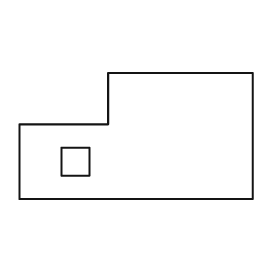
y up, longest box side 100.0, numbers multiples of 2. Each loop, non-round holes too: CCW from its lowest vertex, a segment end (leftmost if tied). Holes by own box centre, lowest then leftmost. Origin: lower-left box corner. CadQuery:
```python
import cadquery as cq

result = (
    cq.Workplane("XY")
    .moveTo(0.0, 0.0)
    .lineTo(100.0, 0.0)
    .lineTo(100.0, 54.0)
    .lineTo(38.0, 54.0)
    .lineTo(38.0, 32.0)
    .lineTo(0.0, 32.0)
    .close()
    .moveTo(18.0, 10.0)
    .lineTo(30.0, 10.0)
    .lineTo(30.0, 22.0)
    .lineTo(18.0, 22.0)
    .close()
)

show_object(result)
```